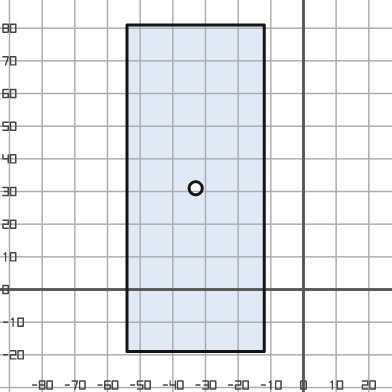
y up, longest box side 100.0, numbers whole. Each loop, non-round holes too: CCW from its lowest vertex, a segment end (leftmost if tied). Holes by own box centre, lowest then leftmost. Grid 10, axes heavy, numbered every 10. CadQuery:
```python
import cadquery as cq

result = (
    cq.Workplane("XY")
    .moveTo(-54.0, -19.0)
    .lineTo(-12.0, -19.0)
    .lineTo(-12.0, 81.0)
    .lineTo(-54.0, 81.0)
    .close()
    .moveTo(-33.0, 31.0)
    .circle(2.0)
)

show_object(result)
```